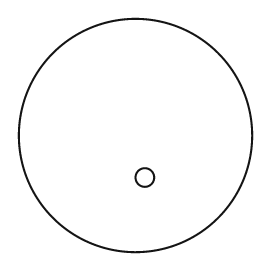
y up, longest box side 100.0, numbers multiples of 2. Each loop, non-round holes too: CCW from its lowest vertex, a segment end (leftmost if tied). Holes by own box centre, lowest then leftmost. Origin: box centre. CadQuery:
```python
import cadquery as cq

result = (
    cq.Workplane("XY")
    .moveTo(0.0, 0.0)
    .circle(50.0)
    .moveTo(4.0, -18.0)
    .circle(4.0)
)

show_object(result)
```